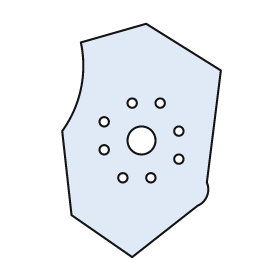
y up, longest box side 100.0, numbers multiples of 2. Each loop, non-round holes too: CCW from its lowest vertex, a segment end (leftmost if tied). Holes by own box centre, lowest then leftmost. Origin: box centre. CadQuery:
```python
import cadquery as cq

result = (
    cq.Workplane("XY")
    .moveTo(-4.0, -50.0)
    .lineTo(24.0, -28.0)
    .threePointArc((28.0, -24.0), (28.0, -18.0))
    .lineTo(34.0, 30.0)
    .lineTo(2.0, 50.0)
    .lineTo(-26.0, 42.0)
    .threePointArc((-26.0, 22.0), (-34.0, 4.0))
    .lineTo(-30.0, -32.0)
    .close()
    .moveTo(-8.0, -16.0)
    .circle(2.0)
    .moveTo(4.0, -16.0)
    .circle(2.0)
    .moveTo(16.0, -8.0)
    .circle(2.0)
    .moveTo(-16.0, -4.0)
    .circle(2.0)
    .moveTo(0.0, 0.0)
    .circle(6.0)
    .moveTo(16.0, 4.0)
    .circle(2.0)
    .moveTo(-16.0, 8.0)
    .circle(2.0)
    .moveTo(-4.0, 16.0)
    .circle(2.0)
    .moveTo(8.0, 16.0)
    .circle(2.0)
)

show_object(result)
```